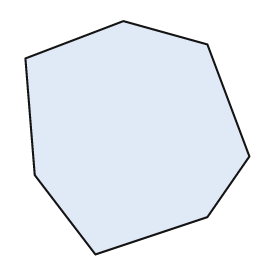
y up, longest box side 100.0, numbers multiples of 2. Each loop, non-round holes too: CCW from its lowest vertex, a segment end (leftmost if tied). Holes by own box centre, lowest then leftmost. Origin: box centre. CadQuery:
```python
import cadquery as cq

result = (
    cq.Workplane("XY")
    .moveTo(-18.0, -50.0)
    .lineTo(30.0, -34.0)
    .lineTo(48.0, -8.0)
    .lineTo(30.0, 40.0)
    .lineTo(-6.0, 50.0)
    .lineTo(-48.0, 34.0)
    .lineTo(-44.0, -16.0)
    .close()
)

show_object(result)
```